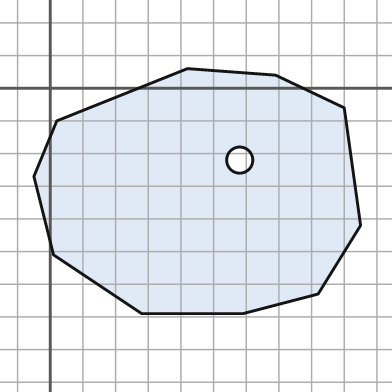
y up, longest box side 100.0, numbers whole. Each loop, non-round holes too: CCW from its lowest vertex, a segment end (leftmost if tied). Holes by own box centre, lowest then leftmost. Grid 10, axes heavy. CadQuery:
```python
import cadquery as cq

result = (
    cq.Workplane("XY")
    .moveTo(28.0, -69.0)
    .lineTo(59.0, -69.0)
    .lineTo(82.0, -63.0)
    .lineTo(95.0, -42.0)
    .lineTo(90.0, -6.0)
    .lineTo(69.0, 4.0)
    .lineTo(42.0, 6.0)
    .lineTo(2.0, -10.0)
    .lineTo(-5.0, -27.0)
    .lineTo(1.0, -51.0)
    .close()
    .moveTo(58.0, -22.0)
    .circle(4.0)
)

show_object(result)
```